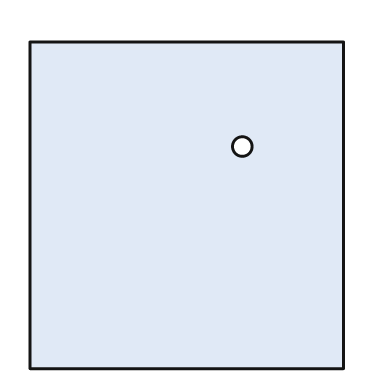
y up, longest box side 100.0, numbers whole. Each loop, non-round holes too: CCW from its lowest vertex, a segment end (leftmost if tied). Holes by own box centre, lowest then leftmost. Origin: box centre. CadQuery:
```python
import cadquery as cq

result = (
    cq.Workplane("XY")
    .moveTo(-48.0, -50.0)
    .lineTo(48.0, -50.0)
    .lineTo(48.0, 50.0)
    .lineTo(-48.0, 50.0)
    .close()
    .moveTo(17.0, 18.0)
    .circle(3.0)
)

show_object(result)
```